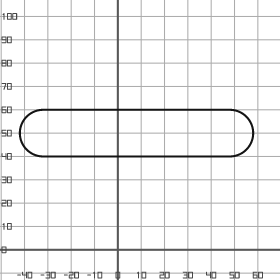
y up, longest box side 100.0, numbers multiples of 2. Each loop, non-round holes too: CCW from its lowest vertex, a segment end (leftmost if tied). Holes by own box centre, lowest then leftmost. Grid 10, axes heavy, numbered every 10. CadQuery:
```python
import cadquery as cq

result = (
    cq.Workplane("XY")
    .moveTo(-32.0, 40.0)
    .lineTo(48.0, 40.0)
    .threePointArc((58.0, 50.0), (48.0, 60.0))
    .lineTo(-32.0, 60.0)
    .threePointArc((-42.0, 50.0), (-32.0, 40.0))
    .close()
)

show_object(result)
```